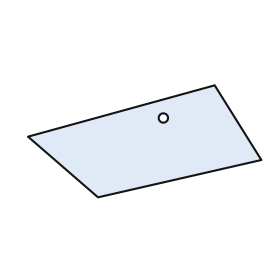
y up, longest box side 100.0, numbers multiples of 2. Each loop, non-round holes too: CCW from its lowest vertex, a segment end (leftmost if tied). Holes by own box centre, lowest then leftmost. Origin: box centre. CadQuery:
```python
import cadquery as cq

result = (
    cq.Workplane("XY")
    .moveTo(-20.0, -24.0)
    .lineTo(50.0, -8.0)
    .lineTo(30.0, 24.0)
    .lineTo(-50.0, 2.0)
    .close()
    .moveTo(8.0, 10.0)
    .circle(2.0)
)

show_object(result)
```